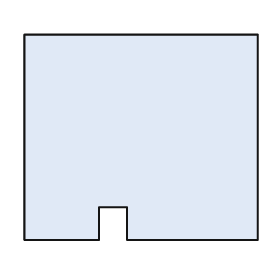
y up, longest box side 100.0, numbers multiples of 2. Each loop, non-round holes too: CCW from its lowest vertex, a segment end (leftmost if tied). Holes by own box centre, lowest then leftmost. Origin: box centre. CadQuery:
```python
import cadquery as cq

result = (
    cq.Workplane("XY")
    .moveTo(-50.0, -44.0)
    .lineTo(-18.0, -44.0)
    .lineTo(-18.0, -30.0)
    .lineTo(-6.0, -30.0)
    .lineTo(-6.0, -44.0)
    .lineTo(50.0, -44.0)
    .lineTo(50.0, 44.0)
    .lineTo(-50.0, 44.0)
    .close()
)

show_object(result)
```